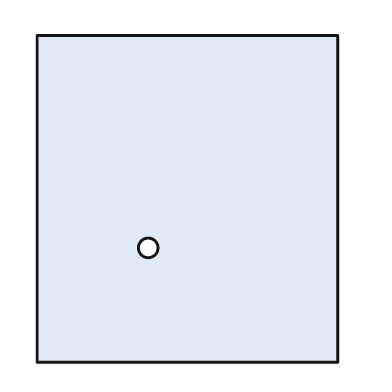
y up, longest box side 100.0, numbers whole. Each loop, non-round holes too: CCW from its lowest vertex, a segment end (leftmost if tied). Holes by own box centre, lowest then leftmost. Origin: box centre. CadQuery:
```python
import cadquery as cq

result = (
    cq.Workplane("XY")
    .moveTo(-46.0, -50.0)
    .lineTo(46.0, -50.0)
    .lineTo(46.0, 50.0)
    .lineTo(-46.0, 50.0)
    .close()
    .moveTo(-12.0, -15.0)
    .circle(3.0)
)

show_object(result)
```